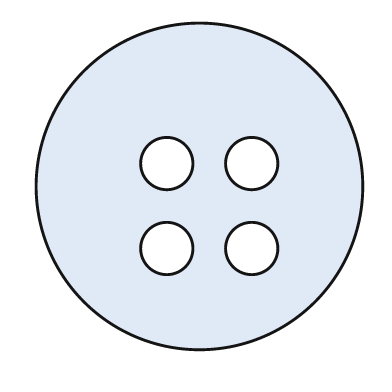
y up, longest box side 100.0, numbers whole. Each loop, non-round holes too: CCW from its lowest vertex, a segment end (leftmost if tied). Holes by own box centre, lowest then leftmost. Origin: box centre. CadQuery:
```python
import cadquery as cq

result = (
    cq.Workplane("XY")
    .moveTo(0.0, 0.0)
    .circle(50.0)
    .moveTo(-10.0, -19.0)
    .circle(8.0)
    .moveTo(16.0, -19.0)
    .circle(8.0)
    .moveTo(-10.0, 7.0)
    .circle(8.0)
    .moveTo(16.0, 7.0)
    .circle(8.0)
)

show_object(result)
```